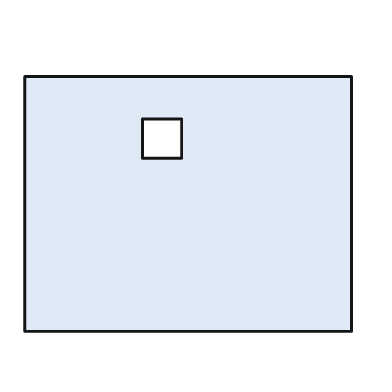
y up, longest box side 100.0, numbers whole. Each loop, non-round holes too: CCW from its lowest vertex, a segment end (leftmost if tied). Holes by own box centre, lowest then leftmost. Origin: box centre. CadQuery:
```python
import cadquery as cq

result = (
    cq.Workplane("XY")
    .moveTo(-50.0, -39.0)
    .lineTo(50.0, -39.0)
    .lineTo(50.0, 39.0)
    .lineTo(-50.0, 39.0)
    .close()
    .moveTo(-14.0, 14.0)
    .lineTo(-2.0, 14.0)
    .lineTo(-2.0, 26.0)
    .lineTo(-14.0, 26.0)
    .close()
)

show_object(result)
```